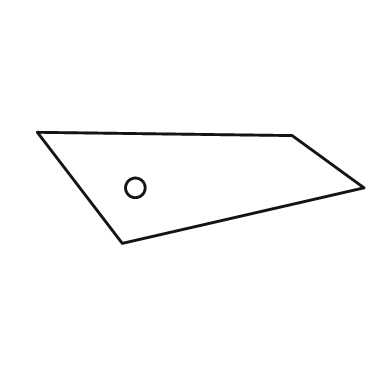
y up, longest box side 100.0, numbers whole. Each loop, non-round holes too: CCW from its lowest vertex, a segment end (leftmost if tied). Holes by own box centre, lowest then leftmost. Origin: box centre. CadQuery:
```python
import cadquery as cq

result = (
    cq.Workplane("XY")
    .moveTo(-24.0, -17.0)
    .lineTo(50.0, 0.0)
    .lineTo(28.0, 16.0)
    .lineTo(-50.0, 17.0)
    .close()
    .moveTo(-20.0, 0.0)
    .circle(3.0)
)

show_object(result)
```